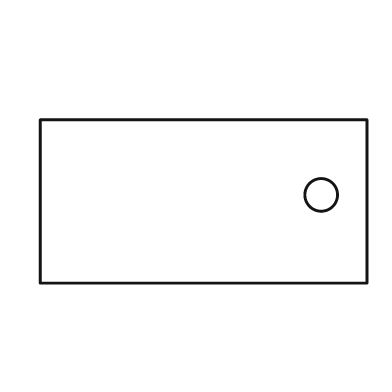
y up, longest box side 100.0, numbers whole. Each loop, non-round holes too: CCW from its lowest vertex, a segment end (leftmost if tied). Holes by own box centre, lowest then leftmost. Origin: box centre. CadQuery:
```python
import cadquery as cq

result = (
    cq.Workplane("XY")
    .moveTo(-50.0, -25.0)
    .lineTo(50.0, -25.0)
    .lineTo(50.0, 25.0)
    .lineTo(-50.0, 25.0)
    .close()
    .moveTo(36.0, 2.0)
    .circle(5.0)
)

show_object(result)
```